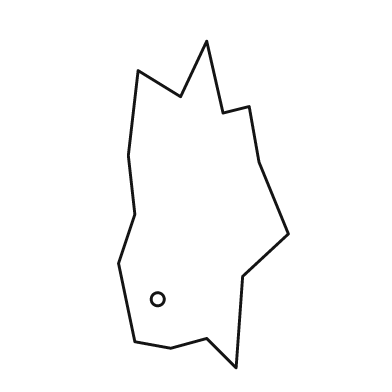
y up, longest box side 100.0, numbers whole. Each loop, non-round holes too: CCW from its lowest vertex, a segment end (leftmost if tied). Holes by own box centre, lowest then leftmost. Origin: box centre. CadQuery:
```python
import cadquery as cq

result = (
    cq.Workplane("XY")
    .moveTo(10.0, -50.0)
    .lineTo(12.0, -22.0)
    .lineTo(26.0, -9.0)
    .lineTo(17.0, 13.0)
    .lineTo(14.0, 30.0)
    .lineTo(6.0, 28.0)
    .lineTo(1.0, 50.0)
    .lineTo(-7.0, 33.0)
    .lineTo(-20.0, 41.0)
    .lineTo(-23.0, 15.0)
    .lineTo(-21.0, -3.0)
    .lineTo(-26.0, -18.0)
    .lineTo(-21.0, -42.0)
    .lineTo(-10.0, -44.0)
    .lineTo(1.0, -41.0)
    .close()
    .moveTo(-14.0, -29.0)
    .circle(2.0)
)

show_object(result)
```